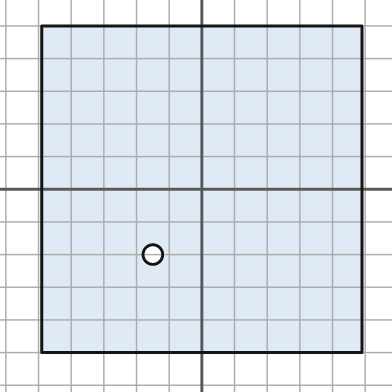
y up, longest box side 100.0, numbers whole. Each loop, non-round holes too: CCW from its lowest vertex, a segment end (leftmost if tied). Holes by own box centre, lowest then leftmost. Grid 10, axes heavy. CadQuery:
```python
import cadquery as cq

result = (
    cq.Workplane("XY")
    .moveTo(-49.0, -50.0)
    .lineTo(49.0, -50.0)
    .lineTo(49.0, 50.0)
    .lineTo(-49.0, 50.0)
    .close()
    .moveTo(-15.0, -20.0)
    .circle(3.0)
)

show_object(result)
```